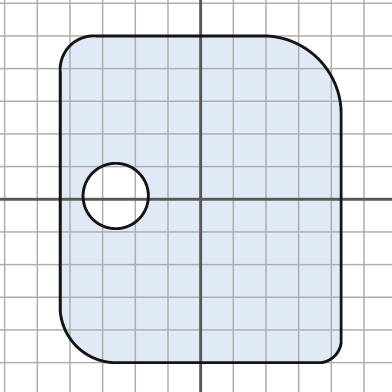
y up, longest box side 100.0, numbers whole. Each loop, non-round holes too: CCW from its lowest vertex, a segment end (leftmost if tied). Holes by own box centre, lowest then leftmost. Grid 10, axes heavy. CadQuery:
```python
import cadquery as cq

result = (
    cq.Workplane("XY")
    .moveTo(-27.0, -50.0)
    .lineTo(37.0, -50.0)
    .threePointArc((41.0, -48.0), (43.0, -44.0))
    .lineTo(43.0, 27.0)
    .threePointArc((36.0, 43.0), (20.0, 50.0))
    .lineTo(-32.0, 50.0)
    .threePointArc((-40.0, 47.0), (-43.0, 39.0))
    .lineTo(-43.0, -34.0)
    .threePointArc((-38.0, -45.0), (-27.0, -50.0))
    .close()
    .moveTo(-26.0, 1.0)
    .circle(10.0)
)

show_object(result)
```